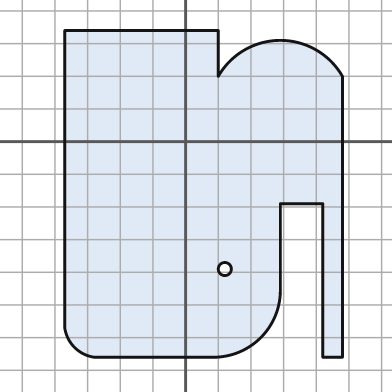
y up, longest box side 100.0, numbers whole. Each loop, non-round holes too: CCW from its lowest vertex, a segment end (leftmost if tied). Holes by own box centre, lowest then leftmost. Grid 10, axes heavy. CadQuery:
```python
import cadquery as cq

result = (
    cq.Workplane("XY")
    .moveTo(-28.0, -66.0)
    .lineTo(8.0, -66.0)
    .threePointArc((23.0, -60.0), (29.0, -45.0))
    .lineTo(29.0, -19.0)
    .lineTo(42.0, -19.0)
    .lineTo(42.0, -66.0)
    .lineTo(48.0, -66.0)
    .lineTo(48.0, 20.0)
    .threePointArc((29.0, 31.0), (10.0, 20.0))
    .lineTo(10.0, 34.0)
    .lineTo(-37.0, 34.0)
    .lineTo(-37.0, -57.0)
    .threePointArc((-34.0, -63.0), (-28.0, -66.0))
    .close()
    .moveTo(12.0, -39.0)
    .circle(2.0)
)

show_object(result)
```